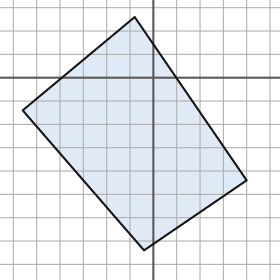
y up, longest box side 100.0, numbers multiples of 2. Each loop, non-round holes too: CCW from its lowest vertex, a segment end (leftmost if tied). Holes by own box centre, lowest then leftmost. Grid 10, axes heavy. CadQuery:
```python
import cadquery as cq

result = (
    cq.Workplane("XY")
    .moveTo(-4.0, -74.0)
    .lineTo(40.0, -44.0)
    .lineTo(-8.0, 26.0)
    .lineTo(-56.0, -14.0)
    .close()
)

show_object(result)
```